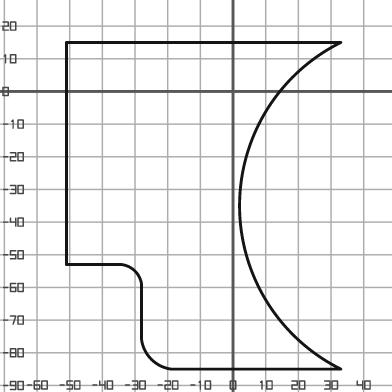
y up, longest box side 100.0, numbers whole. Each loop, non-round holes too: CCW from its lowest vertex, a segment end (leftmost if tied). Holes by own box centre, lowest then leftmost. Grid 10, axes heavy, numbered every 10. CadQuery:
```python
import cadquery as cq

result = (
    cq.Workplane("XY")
    .moveTo(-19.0, -85.0)
    .lineTo(33.0, -85.0)
    .threePointArc((2.0, -35.0), (33.0, 15.0))
    .lineTo(-51.0, 15.0)
    .lineTo(-51.0, -53.0)
    .lineTo(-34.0, -53.0)
    .threePointArc((-30.0, -55.0), (-28.0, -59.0))
    .lineTo(-28.0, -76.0)
    .threePointArc((-25.0, -82.0), (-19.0, -85.0))
    .close()
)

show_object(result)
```